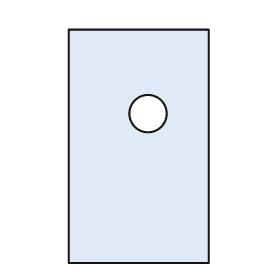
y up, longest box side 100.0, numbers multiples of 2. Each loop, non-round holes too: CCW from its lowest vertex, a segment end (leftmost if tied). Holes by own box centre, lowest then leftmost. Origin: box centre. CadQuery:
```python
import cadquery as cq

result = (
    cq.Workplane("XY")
    .moveTo(-30.0, -50.0)
    .lineTo(30.0, -50.0)
    .lineTo(30.0, 50.0)
    .lineTo(-30.0, 50.0)
    .close()
    .moveTo(4.0, 14.0)
    .circle(8.0)
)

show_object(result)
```